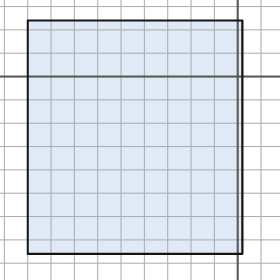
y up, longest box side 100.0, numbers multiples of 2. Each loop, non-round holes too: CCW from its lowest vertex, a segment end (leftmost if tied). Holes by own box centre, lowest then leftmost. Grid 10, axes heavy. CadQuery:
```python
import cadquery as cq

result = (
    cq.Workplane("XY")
    .moveTo(-90.0, -76.0)
    .lineTo(2.0, -76.0)
    .lineTo(2.0, 24.0)
    .lineTo(-90.0, 24.0)
    .close()
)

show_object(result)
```